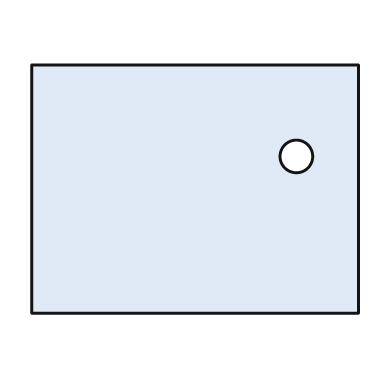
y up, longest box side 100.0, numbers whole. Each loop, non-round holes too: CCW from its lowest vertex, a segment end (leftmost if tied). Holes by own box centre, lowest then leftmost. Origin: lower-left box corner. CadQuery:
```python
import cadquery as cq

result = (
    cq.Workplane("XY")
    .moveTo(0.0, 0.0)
    .lineTo(100.0, 0.0)
    .lineTo(100.0, 76.0)
    .lineTo(0.0, 76.0)
    .close()
    .moveTo(81.0, 48.0)
    .circle(5.0)
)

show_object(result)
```